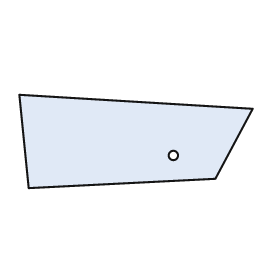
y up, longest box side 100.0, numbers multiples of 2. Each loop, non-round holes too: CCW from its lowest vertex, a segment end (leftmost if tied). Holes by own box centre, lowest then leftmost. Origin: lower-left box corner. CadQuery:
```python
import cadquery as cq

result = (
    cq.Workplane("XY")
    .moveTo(4.0, 0.0)
    .lineTo(84.0, 4.0)
    .lineTo(100.0, 34.0)
    .lineTo(0.0, 40.0)
    .close()
    .moveTo(66.0, 14.0)
    .circle(2.0)
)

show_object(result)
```